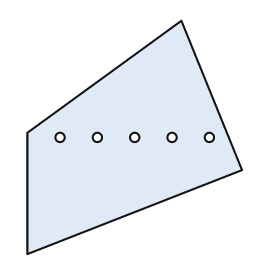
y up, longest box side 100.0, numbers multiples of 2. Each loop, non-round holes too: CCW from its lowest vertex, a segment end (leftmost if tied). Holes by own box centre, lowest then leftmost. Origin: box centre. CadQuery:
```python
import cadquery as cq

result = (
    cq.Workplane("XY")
    .moveTo(-46.0, -50.0)
    .lineTo(46.0, -14.0)
    .lineTo(20.0, 50.0)
    .lineTo(-46.0, 2.0)
    .close()
    .moveTo(-32.0, 0.0)
    .circle(2.0)
    .moveTo(-16.0, 0.0)
    .circle(2.0)
    .moveTo(0.0, 0.0)
    .circle(2.0)
    .moveTo(16.0, 0.0)
    .circle(2.0)
    .moveTo(32.0, 0.0)
    .circle(2.0)
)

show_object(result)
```